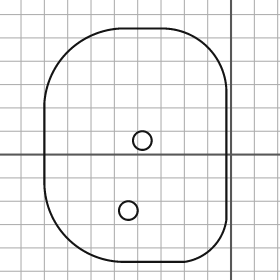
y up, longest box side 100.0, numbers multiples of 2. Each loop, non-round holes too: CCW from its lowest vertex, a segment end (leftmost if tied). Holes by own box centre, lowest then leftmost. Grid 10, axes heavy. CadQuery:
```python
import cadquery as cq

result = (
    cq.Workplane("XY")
    .moveTo(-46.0, -46.0)
    .lineTo(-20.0, -46.0)
    .threePointArc((-8.0, -40.0), (-2.0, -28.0))
    .lineTo(-2.0, 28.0)
    .threePointArc((-10.0, 46.0), (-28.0, 54.0))
    .lineTo(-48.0, 54.0)
    .threePointArc((-70.0, 44.0), (-80.0, 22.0))
    .lineTo(-80.0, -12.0)
    .threePointArc((-70.0, -36.0), (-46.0, -46.0))
    .close()
    .moveTo(-44.0, -24.0)
    .circle(4.0)
    .moveTo(-38.0, 6.0)
    .circle(4.0)
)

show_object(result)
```